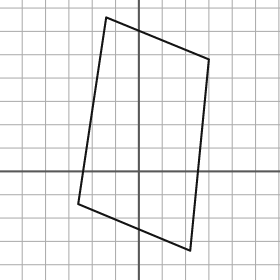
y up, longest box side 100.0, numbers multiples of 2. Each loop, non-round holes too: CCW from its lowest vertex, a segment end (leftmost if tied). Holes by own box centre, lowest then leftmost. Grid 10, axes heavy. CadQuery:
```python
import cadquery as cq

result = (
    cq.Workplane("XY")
    .moveTo(22.0, -34.0)
    .lineTo(30.0, 48.0)
    .lineTo(-14.0, 66.0)
    .lineTo(-26.0, -14.0)
    .close()
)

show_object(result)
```